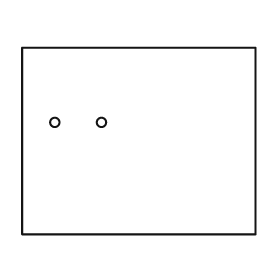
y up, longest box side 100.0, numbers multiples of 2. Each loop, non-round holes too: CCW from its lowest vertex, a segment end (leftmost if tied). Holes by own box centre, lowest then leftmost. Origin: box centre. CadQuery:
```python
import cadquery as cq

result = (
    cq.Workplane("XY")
    .moveTo(-50.0, -40.0)
    .lineTo(50.0, -40.0)
    .lineTo(50.0, 40.0)
    .lineTo(-50.0, 40.0)
    .close()
    .moveTo(-36.0, 8.0)
    .circle(2.0)
    .moveTo(-16.0, 8.0)
    .circle(2.0)
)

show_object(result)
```